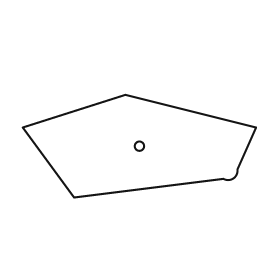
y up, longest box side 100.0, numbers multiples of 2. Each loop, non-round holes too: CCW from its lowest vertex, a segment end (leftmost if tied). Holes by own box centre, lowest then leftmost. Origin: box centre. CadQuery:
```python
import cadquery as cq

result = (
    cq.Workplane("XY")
    .moveTo(-28.0, -22.0)
    .lineTo(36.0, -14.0)
    .threePointArc((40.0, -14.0), (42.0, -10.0))
    .lineTo(50.0, 8.0)
    .lineTo(-6.0, 22.0)
    .lineTo(-50.0, 8.0)
    .close()
    .moveTo(0.0, 0.0)
    .circle(2.0)
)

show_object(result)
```